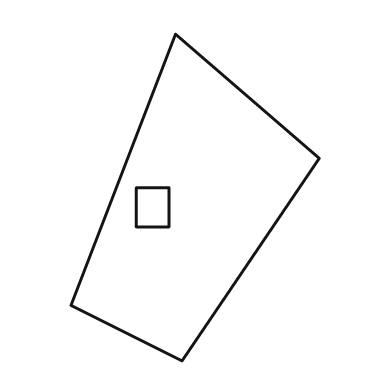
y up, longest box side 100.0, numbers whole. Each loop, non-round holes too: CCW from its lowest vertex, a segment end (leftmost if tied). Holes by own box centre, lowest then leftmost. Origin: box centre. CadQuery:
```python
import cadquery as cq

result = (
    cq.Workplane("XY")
    .moveTo(-4.0, -50.0)
    .lineTo(38.0, 12.0)
    .lineTo(-6.0, 50.0)
    .lineTo(-38.0, -33.0)
    .close()
    .moveTo(-18.0, -9.0)
    .lineTo(-8.0, -9.0)
    .lineTo(-8.0, 3.0)
    .lineTo(-18.0, 3.0)
    .close()
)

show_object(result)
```